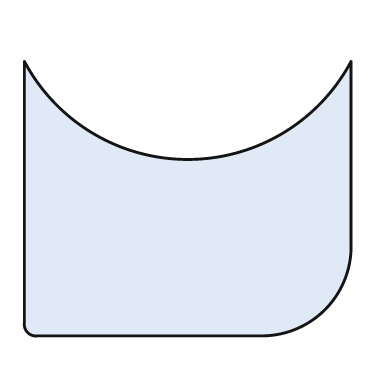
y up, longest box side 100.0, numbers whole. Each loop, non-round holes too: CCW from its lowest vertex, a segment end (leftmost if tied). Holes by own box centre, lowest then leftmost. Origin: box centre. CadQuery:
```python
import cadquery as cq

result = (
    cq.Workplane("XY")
    .moveTo(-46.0, -42.0)
    .lineTo(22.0, -42.0)
    .threePointArc((42.0, -34.0), (50.0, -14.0))
    .lineTo(50.0, 42.0)
    .threePointArc((0.0, 12.0), (-50.0, 42.0))
    .lineTo(-50.0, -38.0)
    .threePointArc((-49.0, -41.0), (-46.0, -42.0))
    .close()
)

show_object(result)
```